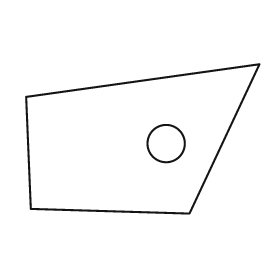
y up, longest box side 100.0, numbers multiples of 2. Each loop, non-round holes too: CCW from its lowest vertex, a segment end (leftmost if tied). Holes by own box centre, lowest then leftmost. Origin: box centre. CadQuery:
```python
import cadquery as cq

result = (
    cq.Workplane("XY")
    .moveTo(20.0, -32.0)
    .lineTo(50.0, 32.0)
    .lineTo(-50.0, 18.0)
    .lineTo(-48.0, -30.0)
    .close()
    .moveTo(10.0, -2.0)
    .circle(8.0)
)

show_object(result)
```